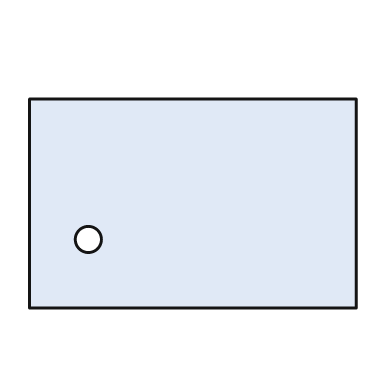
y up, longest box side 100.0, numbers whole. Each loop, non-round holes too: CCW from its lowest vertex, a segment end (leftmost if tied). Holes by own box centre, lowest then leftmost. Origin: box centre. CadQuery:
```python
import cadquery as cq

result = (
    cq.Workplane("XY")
    .moveTo(-50.0, -32.0)
    .lineTo(50.0, -32.0)
    .lineTo(50.0, 32.0)
    .lineTo(-50.0, 32.0)
    .close()
    .moveTo(-32.0, -11.0)
    .circle(4.0)
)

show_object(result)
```